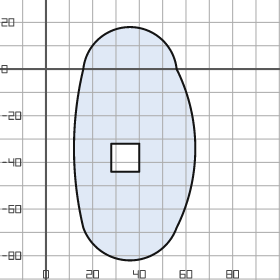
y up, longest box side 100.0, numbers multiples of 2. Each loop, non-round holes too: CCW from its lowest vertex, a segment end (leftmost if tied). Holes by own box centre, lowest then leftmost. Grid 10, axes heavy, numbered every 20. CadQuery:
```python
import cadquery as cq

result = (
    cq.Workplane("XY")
    .moveTo(16.0, -68.0)
    .threePointArc((36.0, -82.0), (56.0, -68.0))
    .threePointArc((64.0, -34.0), (56.0, 0.0))
    .threePointArc((36.0, 18.0), (16.0, 0.0))
    .threePointArc((12.0, -34.0), (16.0, -68.0))
    .close()
    .moveTo(28.0, -44.0)
    .lineTo(40.0, -44.0)
    .lineTo(40.0, -32.0)
    .lineTo(28.0, -32.0)
    .close()
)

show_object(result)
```